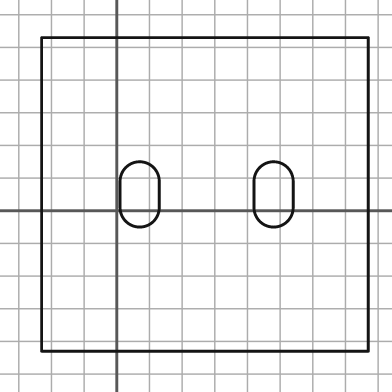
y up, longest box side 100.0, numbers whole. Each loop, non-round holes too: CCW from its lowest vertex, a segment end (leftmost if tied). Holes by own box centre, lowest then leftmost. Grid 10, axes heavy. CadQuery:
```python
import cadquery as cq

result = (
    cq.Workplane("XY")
    .moveTo(-23.0, -43.0)
    .lineTo(77.0, -43.0)
    .lineTo(77.0, 53.0)
    .lineTo(-23.0, 53.0)
    .close()
    .moveTo(1.0, 1.0)
    .threePointArc((7.0, -5.0), (13.0, 1.0))
    .lineTo(13.0, 9.0)
    .threePointArc((7.0, 15.0), (1.0, 9.0))
    .close()
    .moveTo(42.0, 1.0)
    .threePointArc((48.0, -5.0), (54.0, 1.0))
    .lineTo(54.0, 9.0)
    .threePointArc((48.0, 15.0), (42.0, 9.0))
    .close()
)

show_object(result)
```